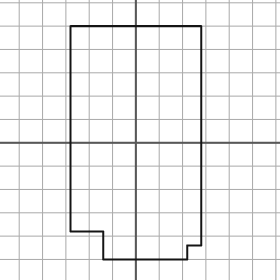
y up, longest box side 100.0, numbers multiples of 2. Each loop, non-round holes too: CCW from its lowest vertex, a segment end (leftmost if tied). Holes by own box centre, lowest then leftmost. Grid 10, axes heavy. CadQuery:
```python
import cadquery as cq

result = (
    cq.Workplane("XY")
    .moveTo(-14.0, -50.0)
    .lineTo(22.0, -50.0)
    .lineTo(22.0, -44.0)
    .lineTo(28.0, -44.0)
    .lineTo(28.0, 50.0)
    .lineTo(-28.0, 50.0)
    .lineTo(-28.0, -38.0)
    .lineTo(-14.0, -38.0)
    .close()
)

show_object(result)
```